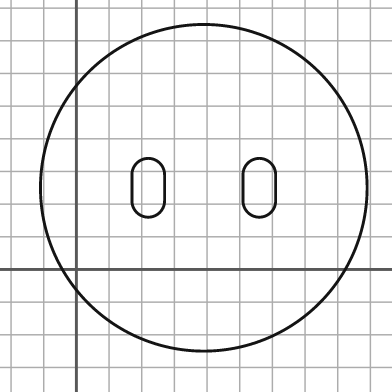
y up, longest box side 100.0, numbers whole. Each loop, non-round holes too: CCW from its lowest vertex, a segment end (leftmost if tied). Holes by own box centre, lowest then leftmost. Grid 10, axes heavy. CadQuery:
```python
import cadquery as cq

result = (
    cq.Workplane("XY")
    .moveTo(39.0, 25.0)
    .circle(50.0)
    .moveTo(17.0, 21.0)
    .threePointArc((22.0, 16.0), (27.0, 21.0))
    .lineTo(27.0, 29.0)
    .threePointArc((22.0, 34.0), (17.0, 29.0))
    .close()
    .moveTo(51.0, 21.0)
    .threePointArc((56.0, 16.0), (61.0, 21.0))
    .lineTo(61.0, 29.0)
    .threePointArc((56.0, 34.0), (51.0, 29.0))
    .close()
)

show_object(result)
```